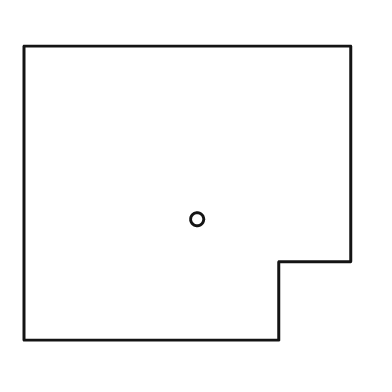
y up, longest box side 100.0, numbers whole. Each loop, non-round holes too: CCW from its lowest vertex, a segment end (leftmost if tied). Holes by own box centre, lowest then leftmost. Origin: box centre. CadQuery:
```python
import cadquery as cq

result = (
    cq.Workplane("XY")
    .moveTo(-50.0, -45.0)
    .lineTo(28.0, -45.0)
    .lineTo(28.0, -21.0)
    .lineTo(50.0, -21.0)
    .lineTo(50.0, 45.0)
    .lineTo(-50.0, 45.0)
    .close()
    .moveTo(3.0, -8.0)
    .circle(2.0)
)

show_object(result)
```